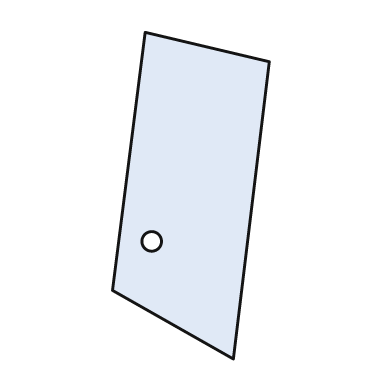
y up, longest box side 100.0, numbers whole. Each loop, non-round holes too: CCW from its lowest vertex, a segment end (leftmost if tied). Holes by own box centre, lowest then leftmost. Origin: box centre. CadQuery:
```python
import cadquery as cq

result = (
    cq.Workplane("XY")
    .moveTo(13.0, -50.0)
    .lineTo(24.0, 41.0)
    .lineTo(-14.0, 50.0)
    .lineTo(-24.0, -29.0)
    .close()
    .moveTo(-12.0, -14.0)
    .circle(3.0)
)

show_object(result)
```